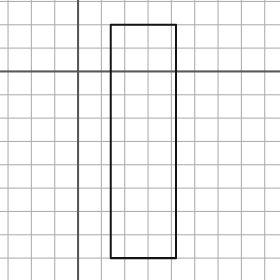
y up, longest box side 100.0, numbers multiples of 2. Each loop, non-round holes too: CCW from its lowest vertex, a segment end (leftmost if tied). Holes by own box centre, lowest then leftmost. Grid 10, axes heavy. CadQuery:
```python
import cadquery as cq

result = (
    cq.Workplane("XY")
    .moveTo(14.0, -80.0)
    .lineTo(42.0, -80.0)
    .lineTo(42.0, 20.0)
    .lineTo(14.0, 20.0)
    .close()
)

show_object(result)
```